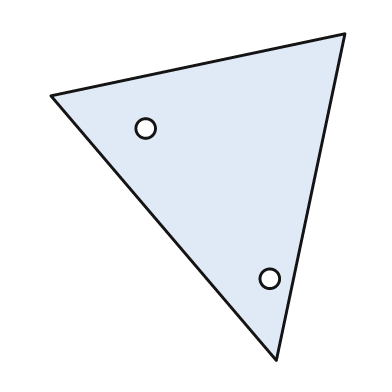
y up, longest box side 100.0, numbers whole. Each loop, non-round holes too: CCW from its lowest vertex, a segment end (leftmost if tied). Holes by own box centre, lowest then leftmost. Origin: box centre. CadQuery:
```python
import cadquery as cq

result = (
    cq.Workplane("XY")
    .moveTo(24.0, -50.0)
    .lineTo(45.0, 50.0)
    .lineTo(-45.0, 31.0)
    .close()
    .moveTo(22.0, -25.0)
    .circle(3.0)
    .moveTo(-16.0, 21.0)
    .circle(3.0)
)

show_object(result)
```